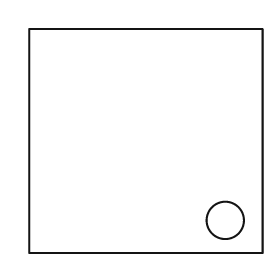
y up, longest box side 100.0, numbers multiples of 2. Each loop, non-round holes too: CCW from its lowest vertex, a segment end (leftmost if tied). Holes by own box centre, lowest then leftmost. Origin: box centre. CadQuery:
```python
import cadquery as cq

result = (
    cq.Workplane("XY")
    .moveTo(-50.0, -48.0)
    .lineTo(50.0, -48.0)
    .lineTo(50.0, 48.0)
    .lineTo(-50.0, 48.0)
    .close()
    .moveTo(34.0, -34.0)
    .circle(8.0)
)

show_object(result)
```